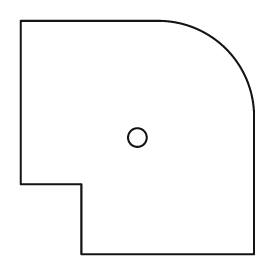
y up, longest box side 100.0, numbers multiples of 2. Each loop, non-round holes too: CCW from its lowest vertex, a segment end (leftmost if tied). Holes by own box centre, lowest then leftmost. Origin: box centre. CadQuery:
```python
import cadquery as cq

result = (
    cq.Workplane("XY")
    .moveTo(-24.0, -50.0)
    .lineTo(50.0, -50.0)
    .lineTo(50.0, 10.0)
    .threePointArc((38.0, 38.0), (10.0, 50.0))
    .lineTo(-50.0, 50.0)
    .lineTo(-50.0, -20.0)
    .lineTo(-24.0, -20.0)
    .close()
    .moveTo(0.0, 0.0)
    .circle(4.0)
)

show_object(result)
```